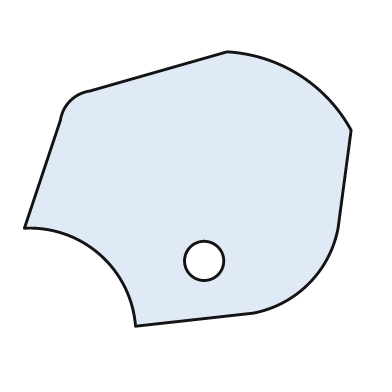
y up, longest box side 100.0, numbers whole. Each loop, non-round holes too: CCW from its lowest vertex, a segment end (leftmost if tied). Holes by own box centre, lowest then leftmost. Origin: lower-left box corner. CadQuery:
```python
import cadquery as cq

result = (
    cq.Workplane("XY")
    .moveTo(34.0, 0.0)
    .lineTo(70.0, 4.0)
    .threePointArc((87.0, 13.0), (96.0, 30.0))
    .lineTo(100.0, 60.0)
    .threePointArc((84.0, 77.0), (62.0, 84.0))
    .lineTo(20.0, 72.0)
    .threePointArc((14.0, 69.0), (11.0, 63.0))
    .lineTo(0.0, 30.0)
    .threePointArc((23.0, 22.0), (34.0, 0.0))
    .close()
    .moveTo(55.0, 20.0)
    .circle(6.0)
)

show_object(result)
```